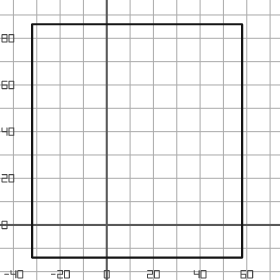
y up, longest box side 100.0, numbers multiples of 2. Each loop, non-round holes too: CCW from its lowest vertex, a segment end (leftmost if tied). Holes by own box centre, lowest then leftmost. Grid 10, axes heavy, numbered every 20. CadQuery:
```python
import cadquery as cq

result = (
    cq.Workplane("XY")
    .moveTo(-32.0, -14.0)
    .lineTo(58.0, -14.0)
    .lineTo(58.0, 86.0)
    .lineTo(-32.0, 86.0)
    .close()
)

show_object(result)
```